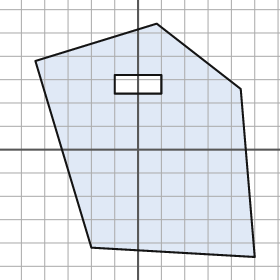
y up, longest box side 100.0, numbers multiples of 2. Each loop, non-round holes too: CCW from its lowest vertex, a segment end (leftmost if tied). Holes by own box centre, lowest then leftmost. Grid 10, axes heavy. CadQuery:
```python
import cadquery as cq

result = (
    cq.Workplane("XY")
    .moveTo(50.0, -46.0)
    .lineTo(44.0, 26.0)
    .lineTo(8.0, 54.0)
    .lineTo(-44.0, 38.0)
    .lineTo(-20.0, -42.0)
    .close()
    .moveTo(-10.0, 24.0)
    .lineTo(10.0, 24.0)
    .lineTo(10.0, 32.0)
    .lineTo(-10.0, 32.0)
    .close()
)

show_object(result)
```